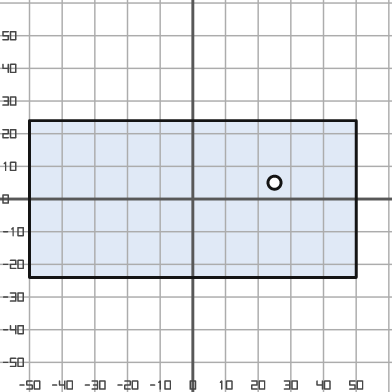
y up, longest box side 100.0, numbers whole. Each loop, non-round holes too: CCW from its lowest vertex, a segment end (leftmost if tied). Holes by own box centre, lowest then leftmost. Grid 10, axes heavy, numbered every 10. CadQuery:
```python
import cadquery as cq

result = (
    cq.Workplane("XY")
    .moveTo(-50.0, -24.0)
    .lineTo(50.0, -24.0)
    .lineTo(50.0, 24.0)
    .lineTo(-50.0, 24.0)
    .close()
    .moveTo(25.0, 5.0)
    .circle(2.0)
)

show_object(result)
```